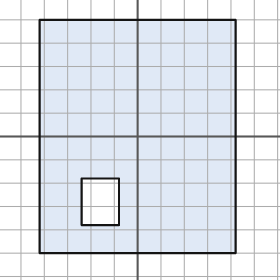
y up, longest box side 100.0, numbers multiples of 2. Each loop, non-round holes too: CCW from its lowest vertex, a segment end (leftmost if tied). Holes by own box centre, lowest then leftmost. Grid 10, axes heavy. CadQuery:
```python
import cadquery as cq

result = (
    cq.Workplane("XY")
    .moveTo(-42.0, -50.0)
    .lineTo(42.0, -50.0)
    .lineTo(42.0, 50.0)
    .lineTo(-42.0, 50.0)
    .close()
    .moveTo(-24.0, -38.0)
    .lineTo(-8.0, -38.0)
    .lineTo(-8.0, -18.0)
    .lineTo(-24.0, -18.0)
    .close()
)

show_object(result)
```